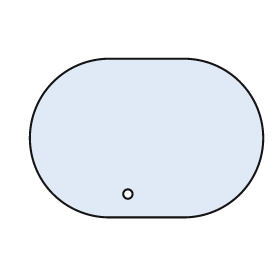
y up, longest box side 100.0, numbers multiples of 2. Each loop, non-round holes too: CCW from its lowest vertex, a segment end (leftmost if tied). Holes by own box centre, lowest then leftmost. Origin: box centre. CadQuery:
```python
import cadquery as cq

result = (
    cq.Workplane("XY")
    .moveTo(-16.0, -34.0)
    .lineTo(16.0, -34.0)
    .threePointArc((50.0, 0.0), (16.0, 34.0))
    .lineTo(-16.0, 34.0)
    .threePointArc((-50.0, 0.0), (-16.0, -34.0))
    .close()
    .moveTo(-8.0, -24.0)
    .circle(2.0)
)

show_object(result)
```